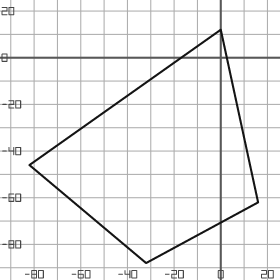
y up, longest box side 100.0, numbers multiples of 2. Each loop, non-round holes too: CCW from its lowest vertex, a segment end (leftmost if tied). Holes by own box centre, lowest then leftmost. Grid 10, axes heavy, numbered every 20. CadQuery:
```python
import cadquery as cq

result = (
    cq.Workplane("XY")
    .moveTo(-32.0, -88.0)
    .lineTo(16.0, -62.0)
    .lineTo(0.0, 12.0)
    .lineTo(-82.0, -46.0)
    .close()
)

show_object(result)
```